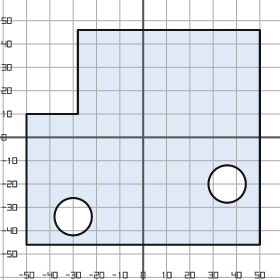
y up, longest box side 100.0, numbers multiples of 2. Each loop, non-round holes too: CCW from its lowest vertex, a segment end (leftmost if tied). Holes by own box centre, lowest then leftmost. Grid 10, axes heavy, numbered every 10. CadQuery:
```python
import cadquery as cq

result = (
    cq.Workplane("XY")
    .moveTo(-50.0, -46.0)
    .lineTo(50.0, -46.0)
    .lineTo(50.0, 46.0)
    .lineTo(-28.0, 46.0)
    .lineTo(-28.0, 10.0)
    .lineTo(-50.0, 10.0)
    .close()
    .moveTo(-30.0, -34.0)
    .circle(8.0)
    .moveTo(36.0, -20.0)
    .circle(8.0)
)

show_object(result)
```